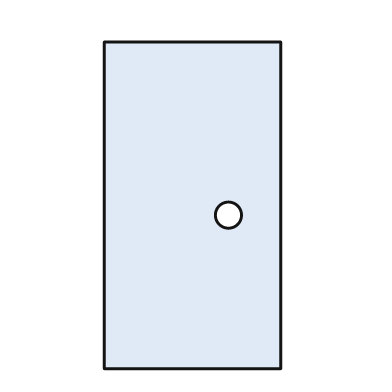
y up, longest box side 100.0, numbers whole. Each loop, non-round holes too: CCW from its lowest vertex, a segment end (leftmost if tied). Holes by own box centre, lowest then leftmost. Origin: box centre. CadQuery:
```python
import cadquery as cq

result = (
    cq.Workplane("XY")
    .moveTo(-27.0, -50.0)
    .lineTo(27.0, -50.0)
    .lineTo(27.0, 50.0)
    .lineTo(-27.0, 50.0)
    .close()
    .moveTo(11.0, -3.0)
    .circle(4.0)
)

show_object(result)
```